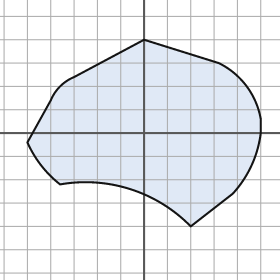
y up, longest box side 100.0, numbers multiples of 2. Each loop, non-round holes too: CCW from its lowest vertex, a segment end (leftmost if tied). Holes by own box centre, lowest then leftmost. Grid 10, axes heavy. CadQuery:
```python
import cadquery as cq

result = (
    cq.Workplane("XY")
    .moveTo(20.0, -40.0)
    .lineTo(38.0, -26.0)
    .threePointArc((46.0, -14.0), (50.0, 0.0))
    .lineTo(50.0, 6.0)
    .threePointArc((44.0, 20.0), (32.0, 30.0))
    .lineTo(0.0, 40.0)
    .lineTo(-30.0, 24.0)
    .threePointArc((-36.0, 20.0), (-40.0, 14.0))
    .lineTo(-50.0, -4.0)
    .threePointArc((-44.0, -14.0), (-36.0, -22.0))
    .threePointArc((-6.0, -24.0), (20.0, -40.0))
    .close()
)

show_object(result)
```